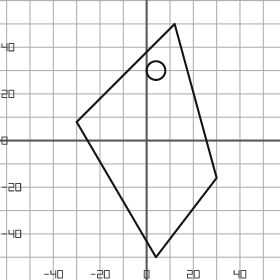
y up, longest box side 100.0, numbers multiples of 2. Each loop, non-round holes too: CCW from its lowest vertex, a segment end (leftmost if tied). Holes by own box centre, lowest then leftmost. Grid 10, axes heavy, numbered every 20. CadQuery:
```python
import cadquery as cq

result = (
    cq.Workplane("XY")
    .moveTo(4.0, -50.0)
    .lineTo(30.0, -16.0)
    .lineTo(12.0, 50.0)
    .lineTo(-30.0, 8.0)
    .close()
    .moveTo(4.0, 30.0)
    .circle(4.0)
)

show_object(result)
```